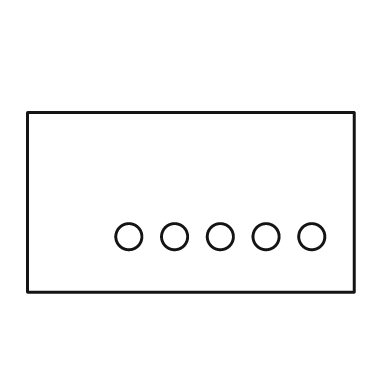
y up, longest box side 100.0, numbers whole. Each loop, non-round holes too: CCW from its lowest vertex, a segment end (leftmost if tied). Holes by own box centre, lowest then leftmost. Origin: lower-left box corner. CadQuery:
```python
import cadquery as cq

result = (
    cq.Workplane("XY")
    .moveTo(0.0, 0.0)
    .lineTo(100.0, 0.0)
    .lineTo(100.0, 55.0)
    .lineTo(0.0, 55.0)
    .close()
    .moveTo(31.0, 17.0)
    .circle(4.0)
    .moveTo(45.0, 17.0)
    .circle(4.0)
    .moveTo(59.0, 17.0)
    .circle(4.0)
    .moveTo(73.0, 17.0)
    .circle(4.0)
    .moveTo(87.0, 17.0)
    .circle(4.0)
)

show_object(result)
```